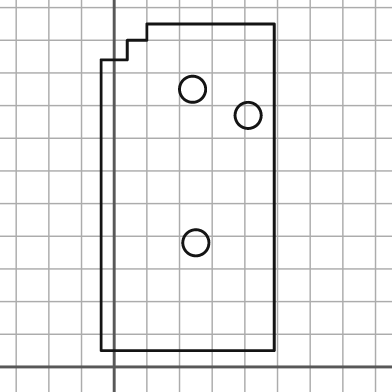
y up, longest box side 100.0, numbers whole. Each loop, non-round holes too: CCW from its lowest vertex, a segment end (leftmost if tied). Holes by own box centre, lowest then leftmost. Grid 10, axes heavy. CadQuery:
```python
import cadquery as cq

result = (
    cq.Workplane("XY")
    .moveTo(-4.0, 5.0)
    .lineTo(49.0, 5.0)
    .lineTo(49.0, 105.0)
    .lineTo(10.0, 105.0)
    .lineTo(10.0, 100.0)
    .lineTo(4.0, 100.0)
    .lineTo(4.0, 94.0)
    .lineTo(-4.0, 94.0)
    .close()
    .moveTo(25.0, 38.0)
    .circle(4.0)
    .moveTo(41.0, 77.0)
    .circle(4.0)
    .moveTo(24.0, 85.0)
    .circle(4.0)
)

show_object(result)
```